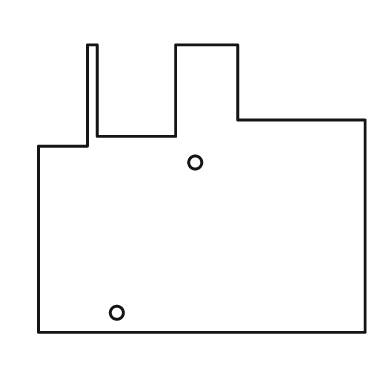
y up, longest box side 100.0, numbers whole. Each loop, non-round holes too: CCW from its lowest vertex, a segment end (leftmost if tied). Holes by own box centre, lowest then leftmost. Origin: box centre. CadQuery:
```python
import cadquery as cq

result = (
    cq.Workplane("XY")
    .moveTo(-50.0, -44.0)
    .lineTo(50.0, -44.0)
    .lineTo(50.0, 21.0)
    .lineTo(11.0, 21.0)
    .lineTo(11.0, 44.0)
    .lineTo(-8.0, 44.0)
    .lineTo(-8.0, 16.0)
    .lineTo(-32.0, 16.0)
    .lineTo(-32.0, 44.0)
    .lineTo(-35.0, 44.0)
    .lineTo(-35.0, 13.0)
    .lineTo(-50.0, 13.0)
    .close()
    .moveTo(-26.0, -38.0)
    .circle(2.0)
    .moveTo(-2.0, 8.0)
    .circle(2.0)
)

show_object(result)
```